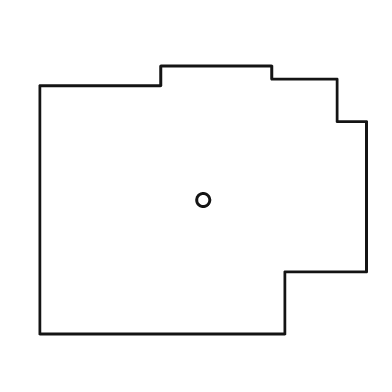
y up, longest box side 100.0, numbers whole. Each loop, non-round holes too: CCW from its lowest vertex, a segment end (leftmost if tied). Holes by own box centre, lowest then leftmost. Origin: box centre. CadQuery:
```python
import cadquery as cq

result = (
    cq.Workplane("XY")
    .moveTo(-50.0, -41.0)
    .lineTo(25.0, -41.0)
    .lineTo(25.0, -22.0)
    .lineTo(50.0, -22.0)
    .lineTo(50.0, 24.0)
    .lineTo(41.0, 24.0)
    .lineTo(41.0, 37.0)
    .lineTo(21.0, 37.0)
    .lineTo(21.0, 41.0)
    .lineTo(-13.0, 41.0)
    .lineTo(-13.0, 35.0)
    .lineTo(-50.0, 35.0)
    .close()
    .moveTo(0.0, 0.0)
    .circle(2.0)
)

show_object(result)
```